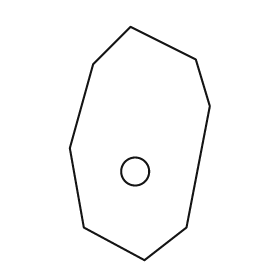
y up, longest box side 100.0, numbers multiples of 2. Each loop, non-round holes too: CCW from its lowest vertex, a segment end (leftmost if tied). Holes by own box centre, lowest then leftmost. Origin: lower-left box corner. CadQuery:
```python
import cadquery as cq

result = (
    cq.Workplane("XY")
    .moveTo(32.0, 0.0)
    .lineTo(50.0, 14.0)
    .lineTo(60.0, 66.0)
    .lineTo(54.0, 86.0)
    .lineTo(26.0, 100.0)
    .lineTo(10.0, 84.0)
    .lineTo(0.0, 48.0)
    .lineTo(6.0, 14.0)
    .close()
    .moveTo(28.0, 38.0)
    .circle(6.0)
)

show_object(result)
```